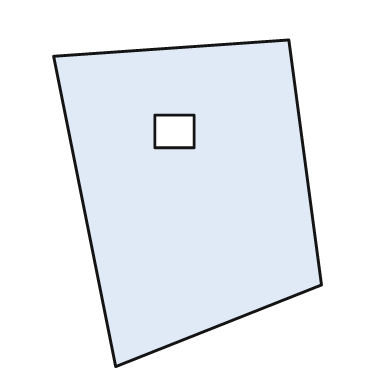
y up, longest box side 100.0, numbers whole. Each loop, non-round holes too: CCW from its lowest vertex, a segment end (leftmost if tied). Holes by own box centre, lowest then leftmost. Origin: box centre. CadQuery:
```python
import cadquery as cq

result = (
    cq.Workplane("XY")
    .moveTo(-22.0, -50.0)
    .lineTo(41.0, -25.0)
    .lineTo(31.0, 50.0)
    .lineTo(-41.0, 45.0)
    .close()
    .moveTo(-10.0, 17.0)
    .lineTo(2.0, 17.0)
    .lineTo(2.0, 27.0)
    .lineTo(-10.0, 27.0)
    .close()
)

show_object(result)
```